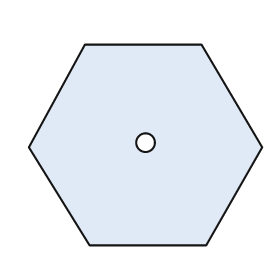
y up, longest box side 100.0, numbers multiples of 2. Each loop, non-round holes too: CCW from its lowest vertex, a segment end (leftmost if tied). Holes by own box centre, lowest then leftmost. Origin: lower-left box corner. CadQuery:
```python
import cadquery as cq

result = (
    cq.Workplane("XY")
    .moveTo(26.0, 0.0)
    .lineTo(76.0, 0.0)
    .lineTo(100.0, 42.0)
    .lineTo(74.0, 86.0)
    .lineTo(24.0, 86.0)
    .lineTo(0.0, 42.0)
    .close()
    .moveTo(50.0, 44.0)
    .circle(4.0)
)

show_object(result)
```